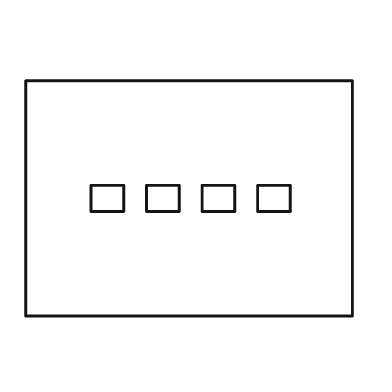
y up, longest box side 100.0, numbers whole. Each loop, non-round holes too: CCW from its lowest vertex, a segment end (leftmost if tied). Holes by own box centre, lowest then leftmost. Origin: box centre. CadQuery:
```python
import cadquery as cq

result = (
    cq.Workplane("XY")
    .moveTo(-50.0, -36.0)
    .lineTo(50.0, -36.0)
    .lineTo(50.0, 36.0)
    .lineTo(-50.0, 36.0)
    .close()
    .moveTo(-30.0, -4.0)
    .lineTo(-20.0, -4.0)
    .lineTo(-20.0, 4.0)
    .lineTo(-30.0, 4.0)
    .close()
    .moveTo(-13.0, -4.0)
    .lineTo(-3.0, -4.0)
    .lineTo(-3.0, 4.0)
    .lineTo(-13.0, 4.0)
    .close()
    .moveTo(4.0, -4.0)
    .lineTo(14.0, -4.0)
    .lineTo(14.0, 4.0)
    .lineTo(4.0, 4.0)
    .close()
    .moveTo(21.0, -4.0)
    .lineTo(31.0, -4.0)
    .lineTo(31.0, 4.0)
    .lineTo(21.0, 4.0)
    .close()
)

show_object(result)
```